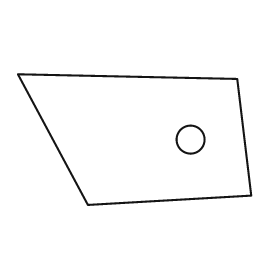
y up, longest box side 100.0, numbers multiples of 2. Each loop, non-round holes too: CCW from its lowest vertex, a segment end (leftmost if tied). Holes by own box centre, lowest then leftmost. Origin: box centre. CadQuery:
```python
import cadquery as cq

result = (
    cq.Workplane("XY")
    .moveTo(-20.0, -28.0)
    .lineTo(50.0, -24.0)
    .lineTo(44.0, 26.0)
    .lineTo(-50.0, 28.0)
    .close()
    .moveTo(24.0, 0.0)
    .circle(6.0)
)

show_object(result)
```